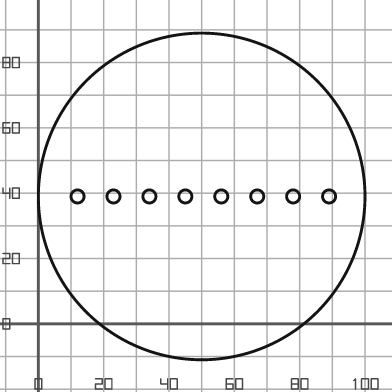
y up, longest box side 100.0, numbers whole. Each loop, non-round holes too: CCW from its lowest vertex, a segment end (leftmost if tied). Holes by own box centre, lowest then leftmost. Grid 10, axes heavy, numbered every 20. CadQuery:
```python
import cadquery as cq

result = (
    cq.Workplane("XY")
    .moveTo(50.0, 39.0)
    .circle(50.0)
    .moveTo(12.0, 39.0)
    .circle(2.0)
    .moveTo(23.0, 39.0)
    .circle(2.0)
    .moveTo(34.0, 39.0)
    .circle(2.0)
    .moveTo(45.0, 39.0)
    .circle(2.0)
    .moveTo(56.0, 39.0)
    .circle(2.0)
    .moveTo(67.0, 39.0)
    .circle(2.0)
    .moveTo(78.0, 39.0)
    .circle(2.0)
    .moveTo(89.0, 39.0)
    .circle(2.0)
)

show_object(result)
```